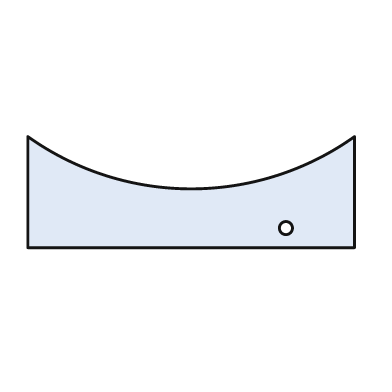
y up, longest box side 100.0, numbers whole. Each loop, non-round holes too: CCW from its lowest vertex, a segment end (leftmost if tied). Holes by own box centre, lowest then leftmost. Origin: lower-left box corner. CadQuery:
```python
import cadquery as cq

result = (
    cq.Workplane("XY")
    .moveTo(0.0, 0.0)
    .lineTo(100.0, 0.0)
    .lineTo(100.0, 34.0)
    .threePointArc((50.0, 18.0), (0.0, 34.0))
    .close()
    .moveTo(79.0, 6.0)
    .circle(2.0)
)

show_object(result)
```